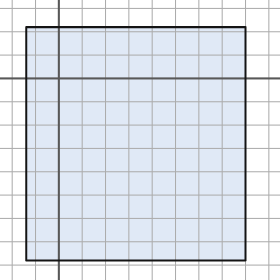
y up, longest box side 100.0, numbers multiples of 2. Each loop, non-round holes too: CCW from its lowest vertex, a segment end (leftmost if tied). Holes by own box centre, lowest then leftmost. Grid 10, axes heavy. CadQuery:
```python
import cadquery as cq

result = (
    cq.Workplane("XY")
    .moveTo(-14.0, -78.0)
    .lineTo(80.0, -78.0)
    .lineTo(80.0, 22.0)
    .lineTo(-14.0, 22.0)
    .close()
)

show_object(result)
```